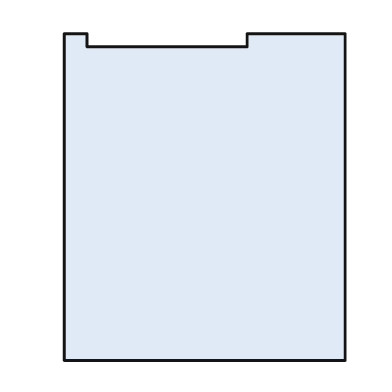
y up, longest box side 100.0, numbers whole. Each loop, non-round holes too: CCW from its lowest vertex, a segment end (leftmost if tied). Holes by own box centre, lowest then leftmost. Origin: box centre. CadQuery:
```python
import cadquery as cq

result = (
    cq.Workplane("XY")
    .moveTo(-43.0, -50.0)
    .lineTo(43.0, -50.0)
    .lineTo(43.0, 50.0)
    .lineTo(13.0, 50.0)
    .lineTo(13.0, 46.0)
    .lineTo(-36.0, 46.0)
    .lineTo(-36.0, 50.0)
    .lineTo(-43.0, 50.0)
    .close()
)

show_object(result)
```